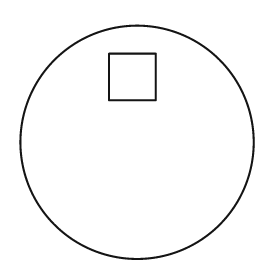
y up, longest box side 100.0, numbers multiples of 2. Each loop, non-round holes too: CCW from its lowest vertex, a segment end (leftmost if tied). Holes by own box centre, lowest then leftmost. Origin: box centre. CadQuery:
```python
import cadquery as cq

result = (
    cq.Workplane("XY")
    .moveTo(0.0, 0.0)
    .circle(50.0)
    .moveTo(-12.0, 18.0)
    .lineTo(8.0, 18.0)
    .lineTo(8.0, 38.0)
    .lineTo(-12.0, 38.0)
    .close()
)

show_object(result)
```